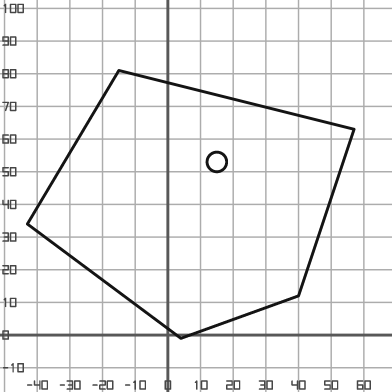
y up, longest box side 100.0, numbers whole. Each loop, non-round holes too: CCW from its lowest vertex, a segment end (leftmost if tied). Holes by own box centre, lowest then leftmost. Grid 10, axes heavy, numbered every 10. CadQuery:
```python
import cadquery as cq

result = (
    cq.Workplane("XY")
    .moveTo(4.0, -1.0)
    .lineTo(40.0, 12.0)
    .lineTo(57.0, 63.0)
    .lineTo(-15.0, 81.0)
    .lineTo(-43.0, 34.0)
    .close()
    .moveTo(15.0, 53.0)
    .circle(3.0)
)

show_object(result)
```